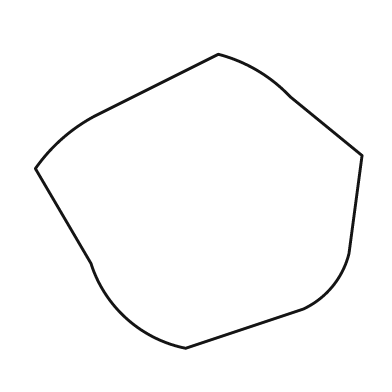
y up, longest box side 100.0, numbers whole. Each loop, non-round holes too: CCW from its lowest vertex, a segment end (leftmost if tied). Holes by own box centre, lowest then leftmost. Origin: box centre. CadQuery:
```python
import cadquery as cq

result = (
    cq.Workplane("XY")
    .moveTo(-4.0, -45.0)
    .lineTo(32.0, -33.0)
    .threePointArc((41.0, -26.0), (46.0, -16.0))
    .lineTo(50.0, 14.0)
    .lineTo(28.0, 32.0)
    .threePointArc((18.0, 40.0), (6.0, 45.0))
    .lineTo(-32.0, 26.0)
    .threePointArc((-42.0, 19.0), (-50.0, 10.0))
    .lineTo(-33.0, -19.0)
    .threePointArc((-22.0, -36.0), (-4.0, -45.0))
    .close()
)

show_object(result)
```